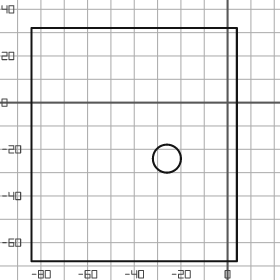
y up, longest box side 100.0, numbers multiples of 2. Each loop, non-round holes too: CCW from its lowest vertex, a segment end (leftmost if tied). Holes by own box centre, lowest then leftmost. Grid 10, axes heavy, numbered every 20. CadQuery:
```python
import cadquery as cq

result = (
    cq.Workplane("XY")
    .moveTo(-84.0, -68.0)
    .lineTo(4.0, -68.0)
    .lineTo(4.0, 32.0)
    .lineTo(-84.0, 32.0)
    .close()
    .moveTo(-26.0, -24.0)
    .circle(6.0)
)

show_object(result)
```